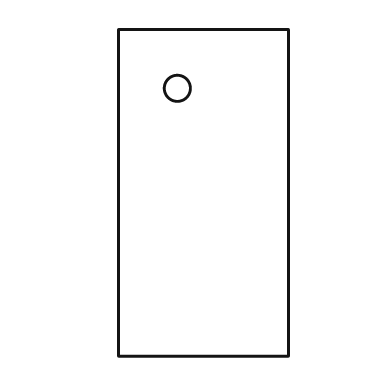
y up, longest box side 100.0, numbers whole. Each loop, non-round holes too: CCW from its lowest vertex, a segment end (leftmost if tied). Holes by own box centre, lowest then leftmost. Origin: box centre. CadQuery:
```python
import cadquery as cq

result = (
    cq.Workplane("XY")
    .moveTo(-26.0, -50.0)
    .lineTo(26.0, -50.0)
    .lineTo(26.0, 50.0)
    .lineTo(-26.0, 50.0)
    .close()
    .moveTo(-8.0, 32.0)
    .circle(4.0)
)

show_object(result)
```